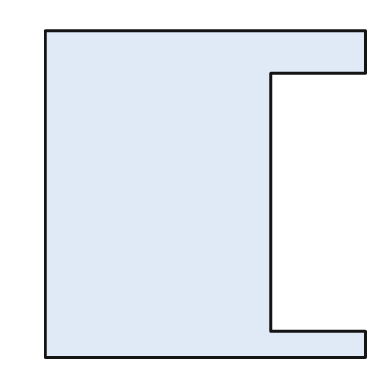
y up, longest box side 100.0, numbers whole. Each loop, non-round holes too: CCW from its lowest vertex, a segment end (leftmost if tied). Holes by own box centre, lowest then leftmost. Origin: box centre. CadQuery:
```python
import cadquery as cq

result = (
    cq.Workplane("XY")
    .moveTo(-49.0, -50.0)
    .lineTo(49.0, -50.0)
    .lineTo(49.0, -42.0)
    .lineTo(20.0, -42.0)
    .lineTo(20.0, 37.0)
    .lineTo(49.0, 37.0)
    .lineTo(49.0, 50.0)
    .lineTo(-49.0, 50.0)
    .close()
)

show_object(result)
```